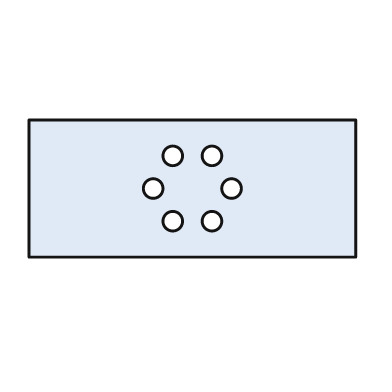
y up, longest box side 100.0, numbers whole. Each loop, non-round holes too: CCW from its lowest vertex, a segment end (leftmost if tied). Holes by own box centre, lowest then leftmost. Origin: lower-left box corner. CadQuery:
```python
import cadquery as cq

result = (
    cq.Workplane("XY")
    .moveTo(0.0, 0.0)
    .lineTo(100.0, 0.0)
    .lineTo(100.0, 42.0)
    .lineTo(0.0, 42.0)
    .close()
    .moveTo(44.0, 11.0)
    .circle(3.0)
    .moveTo(56.0, 11.0)
    .circle(3.0)
    .moveTo(38.0, 21.0)
    .circle(3.0)
    .moveTo(62.0, 21.0)
    .circle(3.0)
    .moveTo(44.0, 31.0)
    .circle(3.0)
    .moveTo(56.0, 31.0)
    .circle(3.0)
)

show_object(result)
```